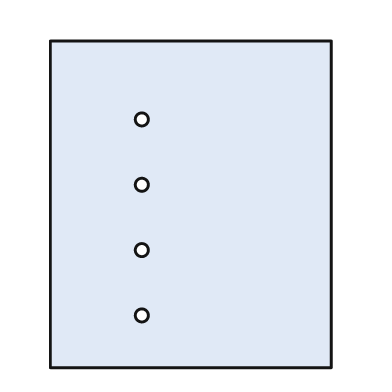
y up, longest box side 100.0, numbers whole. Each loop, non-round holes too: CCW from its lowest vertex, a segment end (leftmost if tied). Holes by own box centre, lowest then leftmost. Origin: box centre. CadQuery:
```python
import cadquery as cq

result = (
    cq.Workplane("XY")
    .moveTo(-43.0, -50.0)
    .lineTo(43.0, -50.0)
    .lineTo(43.0, 50.0)
    .lineTo(-43.0, 50.0)
    .close()
    .moveTo(-15.0, -34.0)
    .circle(2.0)
    .moveTo(-15.0, -14.0)
    .circle(2.0)
    .moveTo(-15.0, 6.0)
    .circle(2.0)
    .moveTo(-15.0, 26.0)
    .circle(2.0)
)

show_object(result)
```